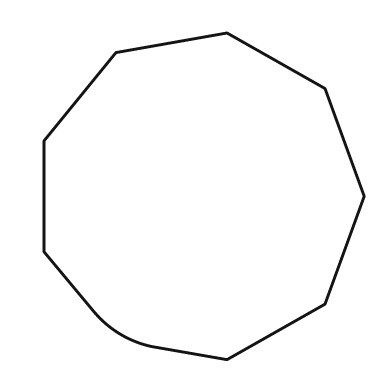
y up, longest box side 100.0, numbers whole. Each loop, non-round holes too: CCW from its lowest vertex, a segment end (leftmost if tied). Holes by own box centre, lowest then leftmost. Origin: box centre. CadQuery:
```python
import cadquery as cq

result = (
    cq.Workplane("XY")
    .moveTo(7.0, -50.0)
    .lineTo(37.0, -33.0)
    .lineTo(49.0, 0.0)
    .lineTo(37.0, 33.0)
    .lineTo(7.0, 50.0)
    .lineTo(-27.0, 44.0)
    .lineTo(-49.0, 17.0)
    .lineTo(-49.0, -17.0)
    .lineTo(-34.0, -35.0)
    .threePointArc((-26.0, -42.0), (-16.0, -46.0))
    .close()
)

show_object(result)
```